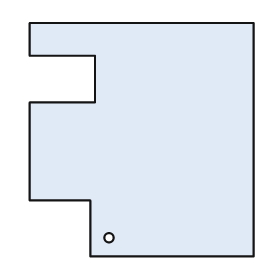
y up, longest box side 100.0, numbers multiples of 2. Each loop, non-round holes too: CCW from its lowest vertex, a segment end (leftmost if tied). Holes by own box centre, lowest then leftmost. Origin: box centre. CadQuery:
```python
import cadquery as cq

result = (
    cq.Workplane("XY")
    .moveTo(-22.0, -50.0)
    .lineTo(48.0, -50.0)
    .lineTo(48.0, 50.0)
    .lineTo(-48.0, 50.0)
    .lineTo(-48.0, 36.0)
    .lineTo(-20.0, 36.0)
    .lineTo(-20.0, 16.0)
    .lineTo(-48.0, 16.0)
    .lineTo(-48.0, -26.0)
    .lineTo(-22.0, -26.0)
    .close()
    .moveTo(-14.0, -42.0)
    .circle(2.0)
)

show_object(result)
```